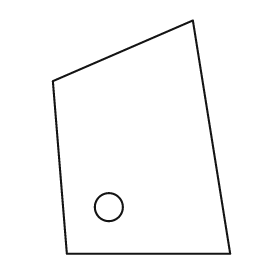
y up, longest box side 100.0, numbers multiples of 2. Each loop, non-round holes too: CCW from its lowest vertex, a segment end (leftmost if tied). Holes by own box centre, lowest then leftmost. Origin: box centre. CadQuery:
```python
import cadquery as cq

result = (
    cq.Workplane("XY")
    .moveTo(-32.0, -50.0)
    .lineTo(38.0, -50.0)
    .lineTo(22.0, 50.0)
    .lineTo(-38.0, 24.0)
    .close()
    .moveTo(-14.0, -30.0)
    .circle(6.0)
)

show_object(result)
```